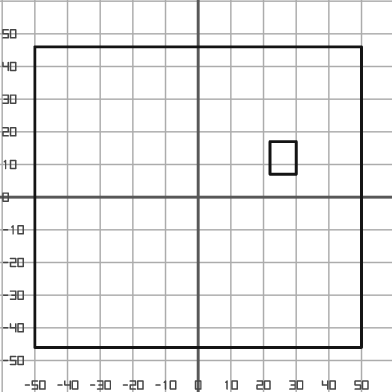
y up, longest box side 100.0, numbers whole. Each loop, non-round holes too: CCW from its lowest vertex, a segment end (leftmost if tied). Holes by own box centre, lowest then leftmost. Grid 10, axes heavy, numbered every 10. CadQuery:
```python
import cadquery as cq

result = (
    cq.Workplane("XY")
    .moveTo(-50.0, -46.0)
    .lineTo(50.0, -46.0)
    .lineTo(50.0, 46.0)
    .lineTo(-50.0, 46.0)
    .close()
    .moveTo(22.0, 7.0)
    .lineTo(30.0, 7.0)
    .lineTo(30.0, 17.0)
    .lineTo(22.0, 17.0)
    .close()
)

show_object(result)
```